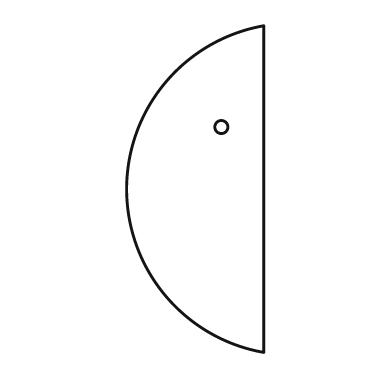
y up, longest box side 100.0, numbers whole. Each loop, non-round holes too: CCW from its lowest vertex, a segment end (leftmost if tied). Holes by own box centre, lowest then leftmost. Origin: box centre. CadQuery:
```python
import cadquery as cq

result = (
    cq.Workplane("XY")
    .moveTo(21.0, -50.0)
    .lineTo(21.0, 50.0)
    .threePointArc((-21.0, 0.0), (21.0, -50.0))
    .close()
    .moveTo(8.0, 19.0)
    .circle(2.0)
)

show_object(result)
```